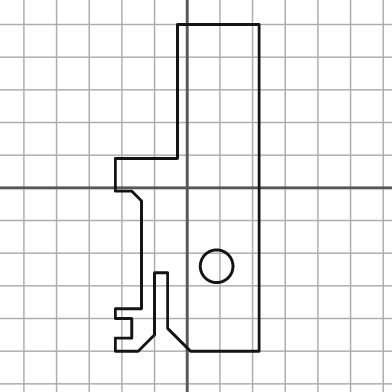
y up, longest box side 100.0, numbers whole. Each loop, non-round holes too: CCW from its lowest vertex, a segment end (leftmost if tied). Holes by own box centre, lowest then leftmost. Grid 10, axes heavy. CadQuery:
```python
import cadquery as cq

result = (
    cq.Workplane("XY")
    .moveTo(-22.0, -50.0)
    .lineTo(-15.0, -50.0)
    .lineTo(-10.0, -45.0)
    .lineTo(-10.0, -26.0)
    .lineTo(-6.0, -26.0)
    .lineTo(-6.0, -43.0)
    .lineTo(1.0, -50.0)
    .lineTo(22.0, -50.0)
    .lineTo(22.0, 50.0)
    .lineTo(-3.0, 50.0)
    .lineTo(-3.0, 9.0)
    .lineTo(-22.0, 9.0)
    .lineTo(-22.0, -1.0)
    .lineTo(-17.0, -1.0)
    .lineTo(-14.0, -4.0)
    .lineTo(-14.0, -37.0)
    .lineTo(-22.0, -37.0)
    .lineTo(-22.0, -40.0)
    .lineTo(-17.0, -40.0)
    .lineTo(-17.0, -46.0)
    .lineTo(-22.0, -46.0)
    .close()
    .moveTo(9.0, -24.0)
    .circle(5.0)
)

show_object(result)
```